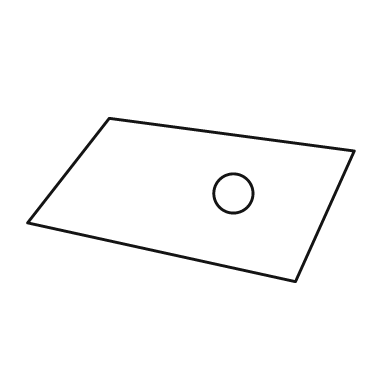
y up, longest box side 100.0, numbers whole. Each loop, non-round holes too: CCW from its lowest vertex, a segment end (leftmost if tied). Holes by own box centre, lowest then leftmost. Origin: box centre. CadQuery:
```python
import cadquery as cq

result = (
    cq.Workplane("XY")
    .moveTo(32.0, -25.0)
    .lineTo(50.0, 15.0)
    .lineTo(-25.0, 25.0)
    .lineTo(-50.0, -7.0)
    .close()
    .moveTo(13.0, 2.0)
    .circle(6.0)
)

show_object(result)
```